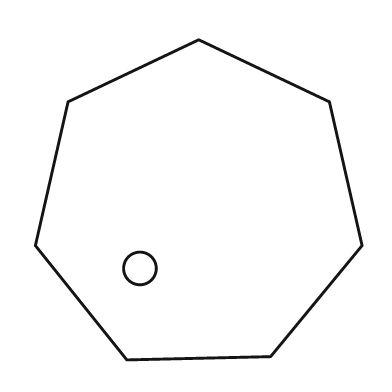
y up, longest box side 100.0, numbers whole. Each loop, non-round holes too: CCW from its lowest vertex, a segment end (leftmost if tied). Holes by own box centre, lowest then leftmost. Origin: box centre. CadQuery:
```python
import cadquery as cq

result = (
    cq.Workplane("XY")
    .moveTo(-22.0, -49.0)
    .lineTo(22.0, -48.0)
    .lineTo(50.0, -14.0)
    .lineTo(40.0, 30.0)
    .lineTo(0.0, 49.0)
    .lineTo(-40.0, 30.0)
    .lineTo(-50.0, -14.0)
    .close()
    .moveTo(-18.0, -21.0)
    .circle(5.0)
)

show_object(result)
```